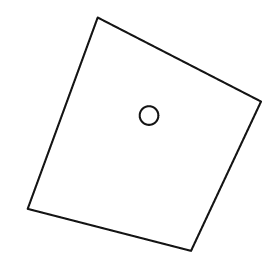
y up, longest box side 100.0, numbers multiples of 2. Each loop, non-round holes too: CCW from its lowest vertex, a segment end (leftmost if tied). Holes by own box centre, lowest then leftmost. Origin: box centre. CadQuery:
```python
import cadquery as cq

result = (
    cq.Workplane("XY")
    .moveTo(20.0, -50.0)
    .lineTo(50.0, 14.0)
    .lineTo(-20.0, 50.0)
    .lineTo(-50.0, -32.0)
    .close()
    .moveTo(2.0, 8.0)
    .circle(4.0)
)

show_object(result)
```